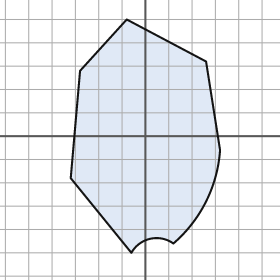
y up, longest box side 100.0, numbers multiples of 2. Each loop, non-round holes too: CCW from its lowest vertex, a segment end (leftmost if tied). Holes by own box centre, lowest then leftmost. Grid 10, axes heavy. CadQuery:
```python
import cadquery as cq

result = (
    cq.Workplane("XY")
    .moveTo(-6.0, -50.0)
    .threePointArc((2.0, -44.0), (12.0, -46.0))
    .threePointArc((26.0, -28.0), (32.0, -6.0))
    .lineTo(26.0, 32.0)
    .lineTo(-8.0, 50.0)
    .lineTo(-28.0, 28.0)
    .lineTo(-32.0, -18.0)
    .close()
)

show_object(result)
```